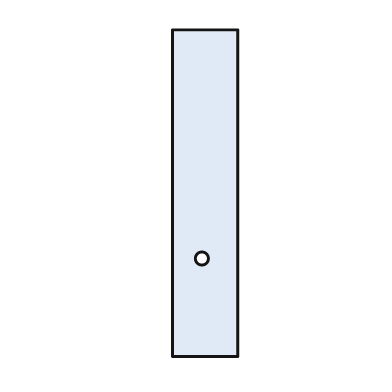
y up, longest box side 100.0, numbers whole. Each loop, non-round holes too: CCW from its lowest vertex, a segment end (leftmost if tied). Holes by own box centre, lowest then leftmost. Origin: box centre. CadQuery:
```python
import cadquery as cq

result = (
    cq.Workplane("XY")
    .moveTo(-10.0, -50.0)
    .lineTo(10.0, -50.0)
    .lineTo(10.0, 50.0)
    .lineTo(-10.0, 50.0)
    .close()
    .moveTo(-1.0, -20.0)
    .circle(2.0)
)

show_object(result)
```